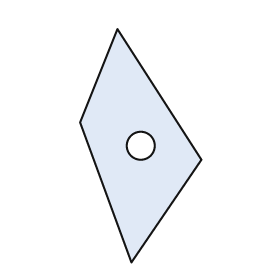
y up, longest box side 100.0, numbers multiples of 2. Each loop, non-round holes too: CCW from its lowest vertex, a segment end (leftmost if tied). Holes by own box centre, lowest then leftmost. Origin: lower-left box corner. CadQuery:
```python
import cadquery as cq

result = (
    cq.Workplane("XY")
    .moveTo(22.0, 0.0)
    .lineTo(52.0, 44.0)
    .lineTo(16.0, 100.0)
    .lineTo(0.0, 60.0)
    .close()
    .moveTo(26.0, 50.0)
    .circle(6.0)
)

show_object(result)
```